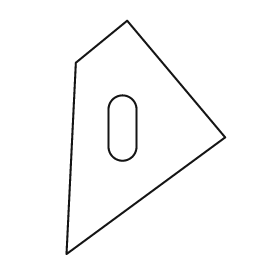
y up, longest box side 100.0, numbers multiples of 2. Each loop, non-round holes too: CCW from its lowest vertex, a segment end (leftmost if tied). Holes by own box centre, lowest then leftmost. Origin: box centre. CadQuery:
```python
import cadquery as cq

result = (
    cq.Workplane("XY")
    .moveTo(-34.0, -50.0)
    .lineTo(34.0, 0.0)
    .lineTo(-8.0, 50.0)
    .lineTo(-30.0, 32.0)
    .close()
    .moveTo(-16.0, -4.0)
    .threePointArc((-10.0, -10.0), (-4.0, -4.0))
    .lineTo(-4.0, 12.0)
    .threePointArc((-10.0, 18.0), (-16.0, 12.0))
    .close()
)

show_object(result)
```